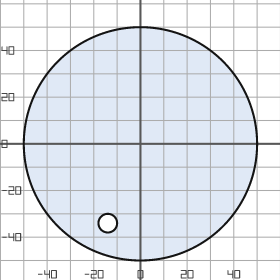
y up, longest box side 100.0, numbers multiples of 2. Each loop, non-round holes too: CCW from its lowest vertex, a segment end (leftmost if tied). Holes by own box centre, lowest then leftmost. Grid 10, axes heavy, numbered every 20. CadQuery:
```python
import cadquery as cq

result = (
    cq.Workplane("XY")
    .moveTo(0.0, 0.0)
    .circle(50.0)
    .moveTo(-14.0, -34.0)
    .circle(4.0)
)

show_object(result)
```